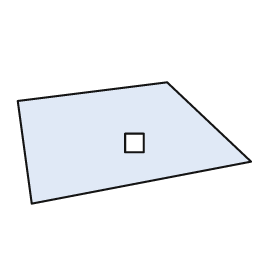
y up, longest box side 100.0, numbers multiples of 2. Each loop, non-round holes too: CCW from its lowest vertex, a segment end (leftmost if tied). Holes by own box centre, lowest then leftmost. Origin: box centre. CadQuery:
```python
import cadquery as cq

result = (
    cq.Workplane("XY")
    .moveTo(-44.0, -26.0)
    .lineTo(50.0, -8.0)
    .lineTo(14.0, 26.0)
    .lineTo(-50.0, 18.0)
    .close()
    .moveTo(-4.0, -4.0)
    .lineTo(4.0, -4.0)
    .lineTo(4.0, 4.0)
    .lineTo(-4.0, 4.0)
    .close()
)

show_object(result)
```